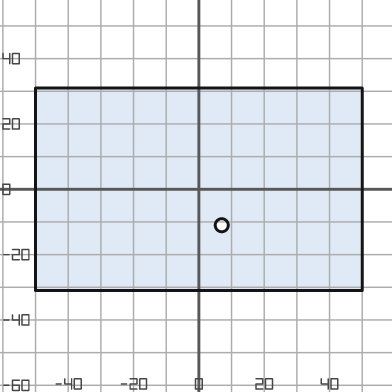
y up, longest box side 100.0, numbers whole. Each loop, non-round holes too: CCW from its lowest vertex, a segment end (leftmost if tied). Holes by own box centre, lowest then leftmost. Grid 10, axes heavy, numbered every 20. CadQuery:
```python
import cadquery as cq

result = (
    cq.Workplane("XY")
    .moveTo(-50.0, -31.0)
    .lineTo(50.0, -31.0)
    .lineTo(50.0, 31.0)
    .lineTo(-50.0, 31.0)
    .close()
    .moveTo(7.0, -11.0)
    .circle(2.0)
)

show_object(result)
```